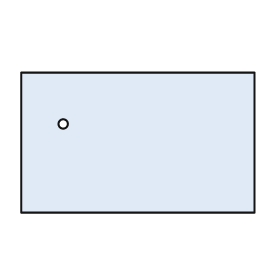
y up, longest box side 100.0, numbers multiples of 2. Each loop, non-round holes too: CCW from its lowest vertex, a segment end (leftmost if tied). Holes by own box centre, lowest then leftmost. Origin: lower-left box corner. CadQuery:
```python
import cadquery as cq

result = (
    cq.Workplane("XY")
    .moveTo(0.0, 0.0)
    .lineTo(100.0, 0.0)
    .lineTo(100.0, 60.0)
    .lineTo(0.0, 60.0)
    .close()
    .moveTo(18.0, 38.0)
    .circle(2.0)
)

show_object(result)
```